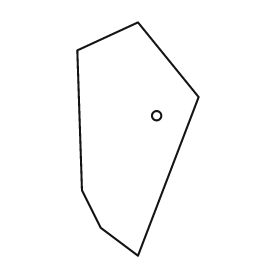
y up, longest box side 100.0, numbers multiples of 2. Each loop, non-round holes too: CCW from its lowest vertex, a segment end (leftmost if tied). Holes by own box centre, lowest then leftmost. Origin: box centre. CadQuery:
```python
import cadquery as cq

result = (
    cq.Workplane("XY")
    .moveTo(0.0, -50.0)
    .lineTo(26.0, 18.0)
    .lineTo(0.0, 50.0)
    .lineTo(-26.0, 38.0)
    .lineTo(-24.0, -22.0)
    .lineTo(-16.0, -38.0)
    .close()
    .moveTo(8.0, 10.0)
    .circle(2.0)
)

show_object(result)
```